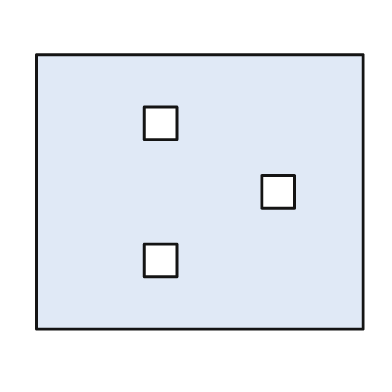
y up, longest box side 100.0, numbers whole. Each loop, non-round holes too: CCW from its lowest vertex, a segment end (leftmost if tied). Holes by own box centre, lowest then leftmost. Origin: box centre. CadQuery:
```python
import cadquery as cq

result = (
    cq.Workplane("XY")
    .moveTo(-50.0, -42.0)
    .lineTo(50.0, -42.0)
    .lineTo(50.0, 42.0)
    .lineTo(-50.0, 42.0)
    .close()
    .moveTo(-17.0, -26.0)
    .lineTo(-7.0, -26.0)
    .lineTo(-7.0, -16.0)
    .lineTo(-17.0, -16.0)
    .close()
    .moveTo(19.0, -5.0)
    .lineTo(29.0, -5.0)
    .lineTo(29.0, 5.0)
    .lineTo(19.0, 5.0)
    .close()
    .moveTo(-17.0, 16.0)
    .lineTo(-7.0, 16.0)
    .lineTo(-7.0, 26.0)
    .lineTo(-17.0, 26.0)
    .close()
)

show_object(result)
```